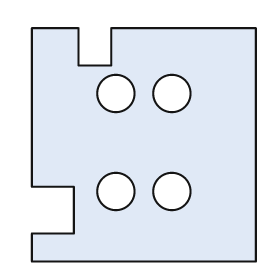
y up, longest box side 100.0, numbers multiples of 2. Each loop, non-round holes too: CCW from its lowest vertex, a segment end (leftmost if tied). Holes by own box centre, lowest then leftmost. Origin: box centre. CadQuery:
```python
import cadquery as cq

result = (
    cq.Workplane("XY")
    .moveTo(-48.0, -50.0)
    .lineTo(48.0, -50.0)
    .lineTo(48.0, 50.0)
    .lineTo(-14.0, 50.0)
    .lineTo(-14.0, 34.0)
    .lineTo(-28.0, 34.0)
    .lineTo(-28.0, 50.0)
    .lineTo(-48.0, 50.0)
    .lineTo(-48.0, -18.0)
    .lineTo(-30.0, -18.0)
    .lineTo(-30.0, -38.0)
    .lineTo(-48.0, -38.0)
    .close()
    .moveTo(-12.0, -20.0)
    .circle(8.0)
    .moveTo(12.0, -20.0)
    .circle(8.0)
    .moveTo(-12.0, 22.0)
    .circle(8.0)
    .moveTo(12.0, 22.0)
    .circle(8.0)
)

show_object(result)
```